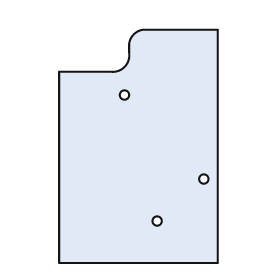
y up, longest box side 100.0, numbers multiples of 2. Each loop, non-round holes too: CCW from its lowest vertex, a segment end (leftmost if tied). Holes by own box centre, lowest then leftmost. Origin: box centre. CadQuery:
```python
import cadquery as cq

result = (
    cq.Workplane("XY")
    .moveTo(-34.0, -50.0)
    .lineTo(34.0, -50.0)
    .lineTo(34.0, 50.0)
    .lineTo(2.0, 50.0)
    .threePointArc((-2.0, 48.0), (-4.0, 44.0))
    .lineTo(-4.0, 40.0)
    .threePointArc((-6.0, 34.0), (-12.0, 32.0))
    .lineTo(-34.0, 32.0)
    .close()
    .moveTo(8.0, -32.0)
    .circle(2.0)
    .moveTo(28.0, -14.0)
    .circle(2.0)
    .moveTo(-6.0, 22.0)
    .circle(2.0)
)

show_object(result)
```